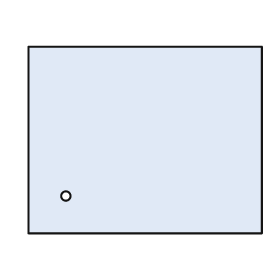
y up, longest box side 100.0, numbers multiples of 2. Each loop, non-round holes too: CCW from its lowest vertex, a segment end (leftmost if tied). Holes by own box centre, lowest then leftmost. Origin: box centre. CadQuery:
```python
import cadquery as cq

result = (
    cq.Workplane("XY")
    .moveTo(-50.0, -40.0)
    .lineTo(50.0, -40.0)
    .lineTo(50.0, 40.0)
    .lineTo(-50.0, 40.0)
    .close()
    .moveTo(-34.0, -24.0)
    .circle(2.0)
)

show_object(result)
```